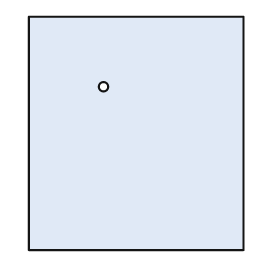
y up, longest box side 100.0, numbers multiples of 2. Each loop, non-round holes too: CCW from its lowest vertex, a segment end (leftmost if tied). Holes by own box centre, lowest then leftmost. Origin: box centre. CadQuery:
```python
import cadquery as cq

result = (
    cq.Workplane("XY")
    .moveTo(-46.0, -50.0)
    .lineTo(46.0, -50.0)
    .lineTo(46.0, 50.0)
    .lineTo(-46.0, 50.0)
    .close()
    .moveTo(-14.0, 20.0)
    .circle(2.0)
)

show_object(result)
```